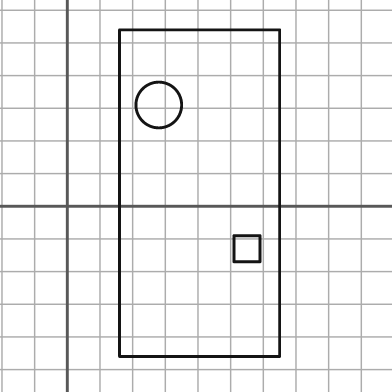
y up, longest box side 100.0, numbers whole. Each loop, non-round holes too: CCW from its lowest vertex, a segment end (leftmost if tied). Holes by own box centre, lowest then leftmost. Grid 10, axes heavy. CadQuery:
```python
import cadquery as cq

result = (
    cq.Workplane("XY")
    .moveTo(16.0, -46.0)
    .lineTo(65.0, -46.0)
    .lineTo(65.0, 54.0)
    .lineTo(16.0, 54.0)
    .close()
    .moveTo(51.0, -17.0)
    .lineTo(59.0, -17.0)
    .lineTo(59.0, -9.0)
    .lineTo(51.0, -9.0)
    .close()
    .moveTo(28.0, 31.0)
    .circle(7.0)
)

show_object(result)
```